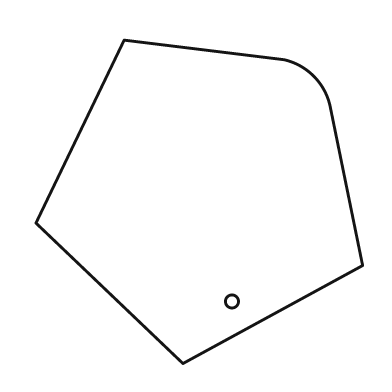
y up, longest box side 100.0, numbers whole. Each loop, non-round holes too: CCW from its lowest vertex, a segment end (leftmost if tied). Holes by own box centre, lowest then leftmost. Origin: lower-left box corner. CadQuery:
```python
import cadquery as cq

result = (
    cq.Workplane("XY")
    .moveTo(45.0, 0.0)
    .lineTo(100.0, 30.0)
    .lineTo(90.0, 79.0)
    .threePointArc((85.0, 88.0), (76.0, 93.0))
    .lineTo(27.0, 99.0)
    .lineTo(0.0, 43.0)
    .close()
    .moveTo(60.0, 19.0)
    .circle(2.0)
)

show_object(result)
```